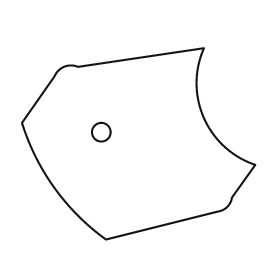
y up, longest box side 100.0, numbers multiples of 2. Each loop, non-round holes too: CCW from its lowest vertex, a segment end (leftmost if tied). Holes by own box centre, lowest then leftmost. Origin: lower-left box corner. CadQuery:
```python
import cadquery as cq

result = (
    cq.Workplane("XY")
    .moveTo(36.0, 0.0)
    .lineTo(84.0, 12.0)
    .threePointArc((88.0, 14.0), (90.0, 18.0))
    .lineTo(100.0, 32.0)
    .threePointArc((78.0, 52.0), (78.0, 82.0))
    .lineTo(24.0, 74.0)
    .threePointArc((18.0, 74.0), (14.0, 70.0))
    .lineTo(0.0, 50.0)
    .threePointArc((14.0, 22.0), (36.0, 0.0))
    .close()
    .moveTo(34.0, 46.0)
    .circle(4.0)
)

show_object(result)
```